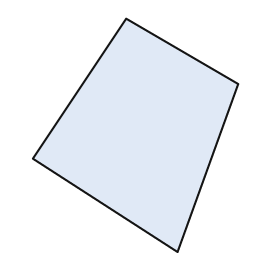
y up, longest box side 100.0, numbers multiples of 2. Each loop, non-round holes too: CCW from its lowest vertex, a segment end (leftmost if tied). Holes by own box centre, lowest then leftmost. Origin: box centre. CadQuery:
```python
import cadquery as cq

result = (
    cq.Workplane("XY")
    .moveTo(18.0, -50.0)
    .lineTo(44.0, 22.0)
    .lineTo(-4.0, 50.0)
    .lineTo(-44.0, -10.0)
    .close()
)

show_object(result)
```